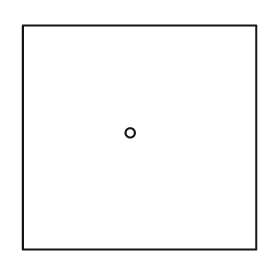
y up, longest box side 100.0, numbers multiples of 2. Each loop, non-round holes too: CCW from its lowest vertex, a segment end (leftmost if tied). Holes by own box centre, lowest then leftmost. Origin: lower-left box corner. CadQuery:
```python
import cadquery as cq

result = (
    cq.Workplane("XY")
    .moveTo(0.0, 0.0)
    .lineTo(100.0, 0.0)
    .lineTo(100.0, 96.0)
    .lineTo(0.0, 96.0)
    .close()
    .moveTo(46.0, 50.0)
    .circle(2.0)
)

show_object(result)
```